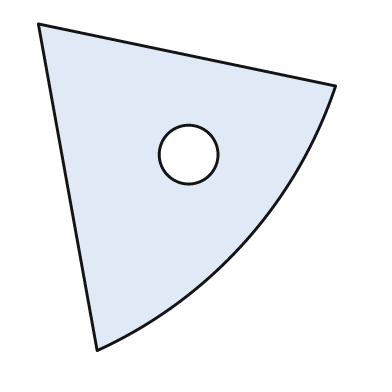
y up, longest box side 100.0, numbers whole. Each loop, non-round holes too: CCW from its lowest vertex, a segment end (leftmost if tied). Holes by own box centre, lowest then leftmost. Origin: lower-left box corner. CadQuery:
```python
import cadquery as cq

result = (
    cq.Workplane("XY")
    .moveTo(18.0, 0.0)
    .threePointArc((63.0, 33.0), (91.0, 81.0))
    .lineTo(0.0, 100.0)
    .close()
    .moveTo(46.0, 60.0)
    .circle(9.0)
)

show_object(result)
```